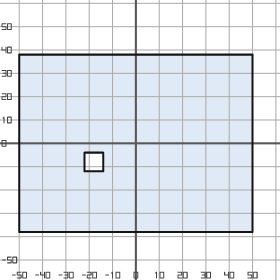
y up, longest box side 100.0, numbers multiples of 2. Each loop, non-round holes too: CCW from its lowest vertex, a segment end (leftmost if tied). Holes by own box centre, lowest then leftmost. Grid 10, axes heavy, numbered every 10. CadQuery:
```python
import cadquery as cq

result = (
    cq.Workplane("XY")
    .moveTo(-50.0, -38.0)
    .lineTo(50.0, -38.0)
    .lineTo(50.0, 38.0)
    .lineTo(-50.0, 38.0)
    .close()
    .moveTo(-22.0, -12.0)
    .lineTo(-14.0, -12.0)
    .lineTo(-14.0, -4.0)
    .lineTo(-22.0, -4.0)
    .close()
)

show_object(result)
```